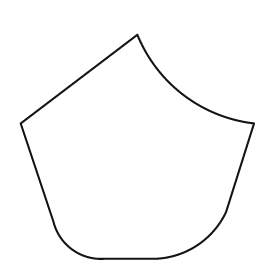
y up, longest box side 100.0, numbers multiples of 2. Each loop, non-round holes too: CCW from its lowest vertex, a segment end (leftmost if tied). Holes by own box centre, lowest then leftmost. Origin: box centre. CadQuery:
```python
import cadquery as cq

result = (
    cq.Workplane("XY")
    .moveTo(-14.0, -48.0)
    .lineTo(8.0, -48.0)
    .threePointArc((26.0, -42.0), (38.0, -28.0))
    .lineTo(50.0, 10.0)
    .threePointArc((20.0, 22.0), (0.0, 48.0))
    .lineTo(-50.0, 10.0)
    .lineTo(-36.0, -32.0)
    .threePointArc((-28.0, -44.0), (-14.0, -48.0))
    .close()
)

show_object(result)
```